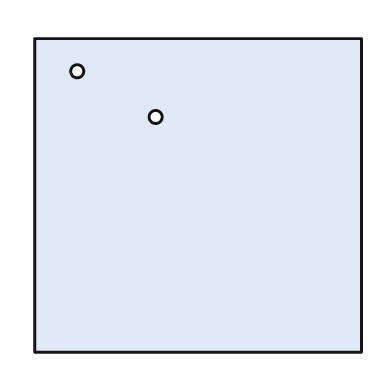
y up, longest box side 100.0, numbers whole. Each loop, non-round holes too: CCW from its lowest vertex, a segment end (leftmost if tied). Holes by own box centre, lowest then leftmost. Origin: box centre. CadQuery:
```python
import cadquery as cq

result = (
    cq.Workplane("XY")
    .moveTo(-50.0, -48.0)
    .lineTo(50.0, -48.0)
    .lineTo(50.0, 48.0)
    .lineTo(-50.0, 48.0)
    .close()
    .moveTo(-13.0, 24.0)
    .circle(2.0)
    .moveTo(-37.0, 38.0)
    .circle(2.0)
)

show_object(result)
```